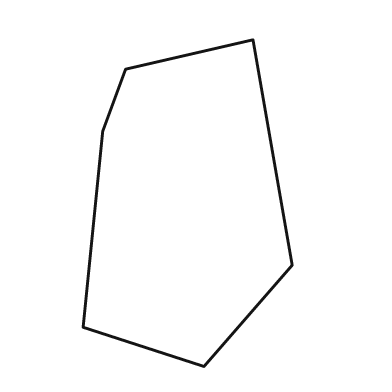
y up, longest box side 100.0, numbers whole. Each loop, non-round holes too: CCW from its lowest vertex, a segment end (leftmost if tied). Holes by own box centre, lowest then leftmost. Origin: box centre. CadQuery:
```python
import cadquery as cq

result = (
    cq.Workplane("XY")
    .moveTo(5.0, -50.0)
    .lineTo(32.0, -19.0)
    .lineTo(20.0, 50.0)
    .lineTo(-19.0, 41.0)
    .lineTo(-26.0, 22.0)
    .lineTo(-32.0, -38.0)
    .close()
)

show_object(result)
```